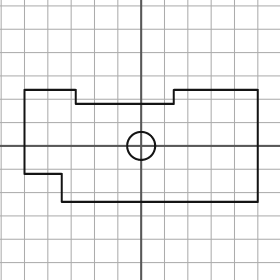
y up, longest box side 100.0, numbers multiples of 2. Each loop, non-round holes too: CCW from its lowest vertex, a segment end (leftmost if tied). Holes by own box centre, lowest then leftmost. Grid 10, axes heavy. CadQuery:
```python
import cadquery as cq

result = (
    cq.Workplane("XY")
    .moveTo(-34.0, -24.0)
    .lineTo(50.0, -24.0)
    .lineTo(50.0, 24.0)
    .lineTo(14.0, 24.0)
    .lineTo(14.0, 18.0)
    .lineTo(-28.0, 18.0)
    .lineTo(-28.0, 24.0)
    .lineTo(-50.0, 24.0)
    .lineTo(-50.0, -12.0)
    .lineTo(-34.0, -12.0)
    .close()
    .moveTo(0.0, 0.0)
    .circle(6.0)
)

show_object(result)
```